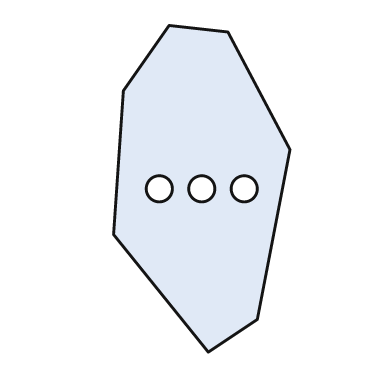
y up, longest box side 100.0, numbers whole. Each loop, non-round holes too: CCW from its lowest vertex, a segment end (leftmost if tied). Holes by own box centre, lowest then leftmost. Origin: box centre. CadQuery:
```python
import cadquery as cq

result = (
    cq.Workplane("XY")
    .moveTo(2.0, -50.0)
    .lineTo(17.0, -40.0)
    .lineTo(27.0, 12.0)
    .lineTo(8.0, 48.0)
    .lineTo(-10.0, 50.0)
    .lineTo(-24.0, 30.0)
    .lineTo(-27.0, -14.0)
    .close()
    .moveTo(-13.0, 0.0)
    .circle(4.0)
    .moveTo(0.0, 0.0)
    .circle(4.0)
    .moveTo(13.0, 0.0)
    .circle(4.0)
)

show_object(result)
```